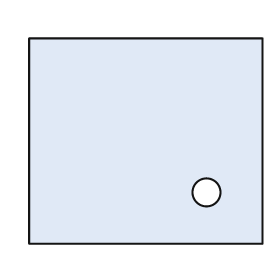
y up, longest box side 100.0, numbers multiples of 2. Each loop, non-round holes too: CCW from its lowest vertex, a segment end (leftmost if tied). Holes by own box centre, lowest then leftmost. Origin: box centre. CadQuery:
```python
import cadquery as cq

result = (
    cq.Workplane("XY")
    .moveTo(-50.0, -44.0)
    .lineTo(50.0, -44.0)
    .lineTo(50.0, 44.0)
    .lineTo(-50.0, 44.0)
    .close()
    .moveTo(26.0, -22.0)
    .circle(6.0)
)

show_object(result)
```